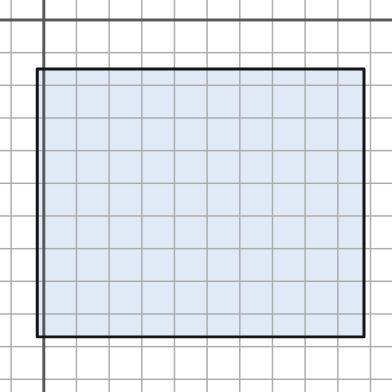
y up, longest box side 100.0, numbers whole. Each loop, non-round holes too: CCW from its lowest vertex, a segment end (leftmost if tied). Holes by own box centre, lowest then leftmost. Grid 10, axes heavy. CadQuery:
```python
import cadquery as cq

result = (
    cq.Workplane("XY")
    .moveTo(-2.0, -97.0)
    .lineTo(98.0, -97.0)
    .lineTo(98.0, -15.0)
    .lineTo(-2.0, -15.0)
    .close()
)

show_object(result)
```